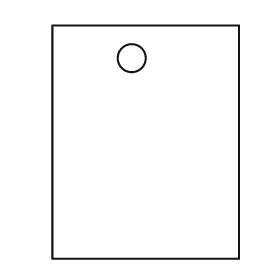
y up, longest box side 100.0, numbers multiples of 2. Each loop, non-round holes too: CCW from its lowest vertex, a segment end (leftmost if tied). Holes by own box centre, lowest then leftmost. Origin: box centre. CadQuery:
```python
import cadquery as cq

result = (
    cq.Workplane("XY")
    .moveTo(-40.0, -50.0)
    .lineTo(40.0, -50.0)
    .lineTo(40.0, 50.0)
    .lineTo(-40.0, 50.0)
    .close()
    .moveTo(-6.0, 36.0)
    .circle(6.0)
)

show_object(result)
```